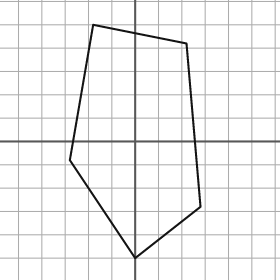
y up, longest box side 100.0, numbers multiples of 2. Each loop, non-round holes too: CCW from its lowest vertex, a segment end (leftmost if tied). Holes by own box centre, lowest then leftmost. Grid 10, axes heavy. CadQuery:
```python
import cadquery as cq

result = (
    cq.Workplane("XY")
    .moveTo(0.0, -50.0)
    .lineTo(28.0, -28.0)
    .lineTo(22.0, 42.0)
    .lineTo(-18.0, 50.0)
    .lineTo(-28.0, -8.0)
    .close()
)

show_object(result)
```